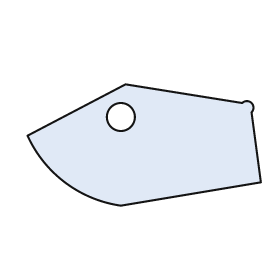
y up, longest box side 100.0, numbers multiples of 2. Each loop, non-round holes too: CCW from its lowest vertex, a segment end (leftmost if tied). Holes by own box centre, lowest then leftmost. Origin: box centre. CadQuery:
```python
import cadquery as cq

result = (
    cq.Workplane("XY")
    .moveTo(-10.0, -26.0)
    .lineTo(50.0, -16.0)
    .lineTo(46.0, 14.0)
    .threePointArc((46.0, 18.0), (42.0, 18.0))
    .lineTo(-8.0, 26.0)
    .lineTo(-50.0, 4.0)
    .threePointArc((-34.0, -16.0), (-10.0, -26.0))
    .close()
    .moveTo(-10.0, 12.0)
    .circle(6.0)
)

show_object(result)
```